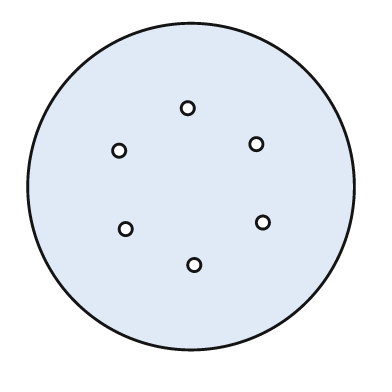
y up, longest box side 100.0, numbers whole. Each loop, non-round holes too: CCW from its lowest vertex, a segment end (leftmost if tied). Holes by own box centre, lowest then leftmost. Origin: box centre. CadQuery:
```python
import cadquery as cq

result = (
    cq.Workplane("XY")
    .moveTo(0.0, 0.0)
    .circle(50.0)
    .moveTo(1.0, -24.0)
    .circle(2.0)
    .moveTo(-20.0, -13.0)
    .circle(2.0)
    .moveTo(22.0, -11.0)
    .circle(2.0)
    .moveTo(-22.0, 11.0)
    .circle(2.0)
    .moveTo(20.0, 13.0)
    .circle(2.0)
    .moveTo(-1.0, 24.0)
    .circle(2.0)
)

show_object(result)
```